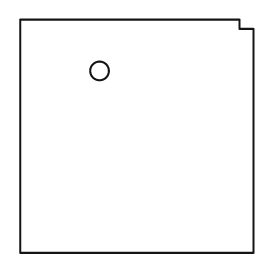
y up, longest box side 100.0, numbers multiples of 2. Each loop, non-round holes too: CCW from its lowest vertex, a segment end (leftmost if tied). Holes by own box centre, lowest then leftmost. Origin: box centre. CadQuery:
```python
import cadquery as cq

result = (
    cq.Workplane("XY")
    .moveTo(-50.0, -50.0)
    .lineTo(50.0, -50.0)
    .lineTo(50.0, 46.0)
    .lineTo(44.0, 46.0)
    .lineTo(44.0, 50.0)
    .lineTo(-50.0, 50.0)
    .close()
    .moveTo(-16.0, 28.0)
    .circle(4.0)
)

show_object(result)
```